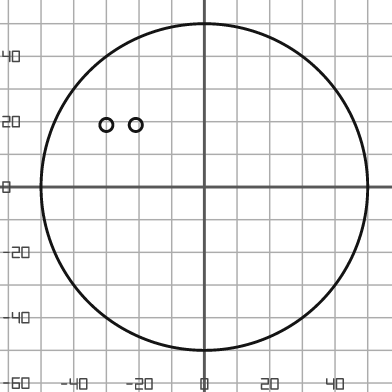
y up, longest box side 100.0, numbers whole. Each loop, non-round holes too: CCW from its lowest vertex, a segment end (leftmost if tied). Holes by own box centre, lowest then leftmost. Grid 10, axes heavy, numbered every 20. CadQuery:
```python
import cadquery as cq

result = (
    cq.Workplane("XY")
    .moveTo(0.0, 0.0)
    .circle(50.0)
    .moveTo(-30.0, 19.0)
    .circle(2.0)
    .moveTo(-21.0, 19.0)
    .circle(2.0)
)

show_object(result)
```